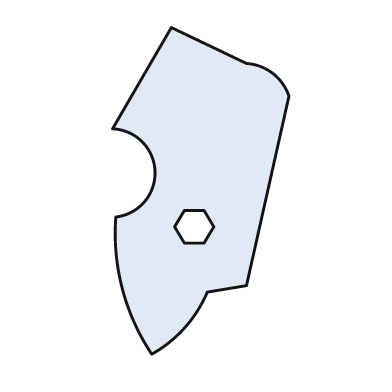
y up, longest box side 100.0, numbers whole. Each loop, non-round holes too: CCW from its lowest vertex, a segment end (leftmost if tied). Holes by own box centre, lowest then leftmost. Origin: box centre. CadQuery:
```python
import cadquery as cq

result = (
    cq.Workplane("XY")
    .moveTo(-15.0, -50.0)
    .threePointArc((-5.0, -42.0), (2.0, -31.0))
    .lineTo(14.0, -29.0)
    .lineTo(27.0, 29.0)
    .threePointArc((22.0, 36.0), (14.0, 39.0))
    .lineTo(-9.0, 50.0)
    .lineTo(-27.0, 19.0)
    .threePointArc((-14.0, 6.0), (-26.0, -8.0))
    .threePointArc((-24.0, -30.0), (-15.0, -50.0))
    .close()
    .moveTo(-5.0, -16.0)
    .lineTo(1.0, -16.0)
    .lineTo(4.0, -11.0)
    .lineTo(1.0, -6.0)
    .lineTo(-5.0, -6.0)
    .lineTo(-8.0, -11.0)
    .close()
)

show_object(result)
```